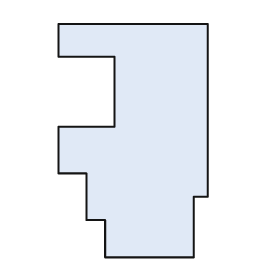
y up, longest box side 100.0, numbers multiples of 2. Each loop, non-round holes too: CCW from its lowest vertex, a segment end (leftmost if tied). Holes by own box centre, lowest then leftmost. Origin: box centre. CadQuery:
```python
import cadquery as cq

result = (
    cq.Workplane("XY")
    .moveTo(-12.0, -50.0)
    .lineTo(26.0, -50.0)
    .lineTo(26.0, -24.0)
    .lineTo(32.0, -24.0)
    .lineTo(32.0, 50.0)
    .lineTo(-32.0, 50.0)
    .lineTo(-32.0, 36.0)
    .lineTo(-8.0, 36.0)
    .lineTo(-8.0, 6.0)
    .lineTo(-32.0, 6.0)
    .lineTo(-32.0, -14.0)
    .lineTo(-20.0, -14.0)
    .lineTo(-20.0, -34.0)
    .lineTo(-12.0, -34.0)
    .close()
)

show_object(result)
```